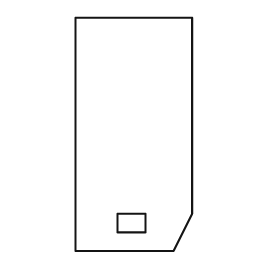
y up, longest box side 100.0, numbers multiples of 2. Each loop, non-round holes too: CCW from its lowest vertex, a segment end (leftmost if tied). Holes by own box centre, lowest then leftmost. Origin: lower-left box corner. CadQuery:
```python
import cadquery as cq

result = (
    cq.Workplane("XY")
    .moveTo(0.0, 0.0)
    .lineTo(42.0, 0.0)
    .lineTo(50.0, 16.0)
    .lineTo(50.0, 100.0)
    .lineTo(0.0, 100.0)
    .close()
    .moveTo(18.0, 8.0)
    .lineTo(30.0, 8.0)
    .lineTo(30.0, 16.0)
    .lineTo(18.0, 16.0)
    .close()
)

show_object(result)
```